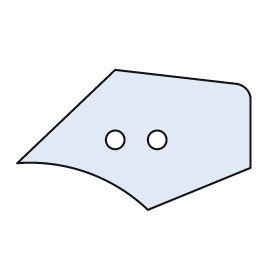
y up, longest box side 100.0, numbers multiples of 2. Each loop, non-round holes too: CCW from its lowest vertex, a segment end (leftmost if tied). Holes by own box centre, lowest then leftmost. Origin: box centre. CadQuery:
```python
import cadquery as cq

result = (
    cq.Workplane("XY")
    .moveTo(6.0, -30.0)
    .lineTo(50.0, -12.0)
    .lineTo(50.0, 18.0)
    .threePointArc((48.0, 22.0), (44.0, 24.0))
    .lineTo(-8.0, 30.0)
    .lineTo(-50.0, -10.0)
    .threePointArc((-20.0, -14.0), (6.0, -30.0))
    .close()
    .moveTo(-8.0, 0.0)
    .circle(4.0)
    .moveTo(10.0, 0.0)
    .circle(4.0)
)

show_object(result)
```